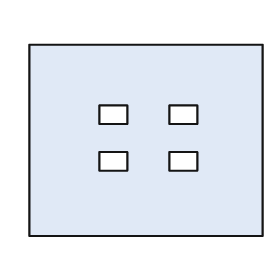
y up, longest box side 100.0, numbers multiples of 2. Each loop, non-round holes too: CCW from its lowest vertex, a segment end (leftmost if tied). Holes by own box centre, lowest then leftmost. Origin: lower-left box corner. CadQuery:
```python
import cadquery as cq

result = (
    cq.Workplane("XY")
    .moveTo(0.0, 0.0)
    .lineTo(100.0, 0.0)
    .lineTo(100.0, 82.0)
    .lineTo(0.0, 82.0)
    .close()
    .moveTo(30.0, 28.0)
    .lineTo(42.0, 28.0)
    .lineTo(42.0, 36.0)
    .lineTo(30.0, 36.0)
    .close()
    .moveTo(60.0, 28.0)
    .lineTo(72.0, 28.0)
    .lineTo(72.0, 36.0)
    .lineTo(60.0, 36.0)
    .close()
    .moveTo(30.0, 48.0)
    .lineTo(42.0, 48.0)
    .lineTo(42.0, 56.0)
    .lineTo(30.0, 56.0)
    .close()
    .moveTo(60.0, 48.0)
    .lineTo(72.0, 48.0)
    .lineTo(72.0, 56.0)
    .lineTo(60.0, 56.0)
    .close()
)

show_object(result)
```